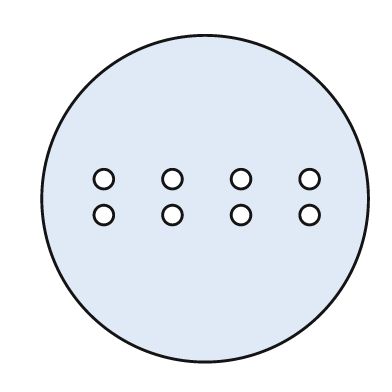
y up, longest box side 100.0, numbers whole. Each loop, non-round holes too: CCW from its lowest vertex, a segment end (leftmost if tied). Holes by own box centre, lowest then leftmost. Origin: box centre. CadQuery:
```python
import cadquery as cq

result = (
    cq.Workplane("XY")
    .moveTo(0.0, 0.0)
    .circle(50.0)
    .moveTo(-31.0, -5.0)
    .circle(3.0)
    .moveTo(-10.0, -5.0)
    .circle(3.0)
    .moveTo(11.0, -5.0)
    .circle(3.0)
    .moveTo(32.0, -5.0)
    .circle(3.0)
    .moveTo(-31.0, 6.0)
    .circle(3.0)
    .moveTo(-10.0, 6.0)
    .circle(3.0)
    .moveTo(11.0, 6.0)
    .circle(3.0)
    .moveTo(32.0, 6.0)
    .circle(3.0)
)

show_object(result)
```